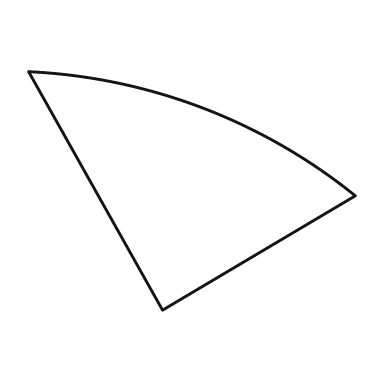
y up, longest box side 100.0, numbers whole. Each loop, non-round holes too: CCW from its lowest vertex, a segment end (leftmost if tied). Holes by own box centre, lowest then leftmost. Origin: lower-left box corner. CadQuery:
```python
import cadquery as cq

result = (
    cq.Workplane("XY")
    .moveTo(41.0, 0.0)
    .lineTo(100.0, 35.0)
    .threePointArc((53.0, 62.0), (0.0, 73.0))
    .close()
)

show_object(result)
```